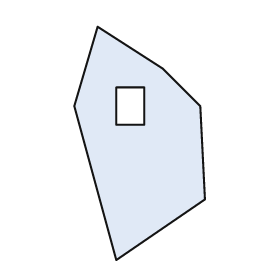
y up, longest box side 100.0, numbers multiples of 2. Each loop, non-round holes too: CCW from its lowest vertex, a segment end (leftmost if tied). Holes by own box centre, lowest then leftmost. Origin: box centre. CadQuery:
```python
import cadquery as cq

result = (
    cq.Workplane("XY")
    .moveTo(-10.0, -50.0)
    .lineTo(28.0, -24.0)
    .lineTo(26.0, 16.0)
    .lineTo(10.0, 32.0)
    .lineTo(-18.0, 50.0)
    .lineTo(-28.0, 16.0)
    .close()
    .moveTo(-10.0, 8.0)
    .lineTo(2.0, 8.0)
    .lineTo(2.0, 24.0)
    .lineTo(-10.0, 24.0)
    .close()
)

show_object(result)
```